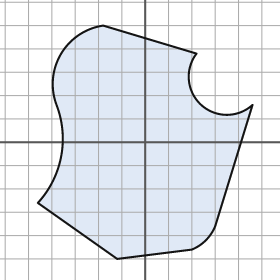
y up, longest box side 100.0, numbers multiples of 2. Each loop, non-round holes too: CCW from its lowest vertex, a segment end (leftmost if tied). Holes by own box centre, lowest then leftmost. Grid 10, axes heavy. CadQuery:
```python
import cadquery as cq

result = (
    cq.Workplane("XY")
    .moveTo(-12.0, -50.0)
    .lineTo(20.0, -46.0)
    .threePointArc((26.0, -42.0), (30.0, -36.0))
    .lineTo(46.0, 16.0)
    .threePointArc((24.0, 16.0), (22.0, 38.0))
    .lineTo(-18.0, 50.0)
    .threePointArc((-36.0, 38.0), (-38.0, 16.0))
    .threePointArc((-36.0, -6.0), (-46.0, -26.0))
    .close()
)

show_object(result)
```